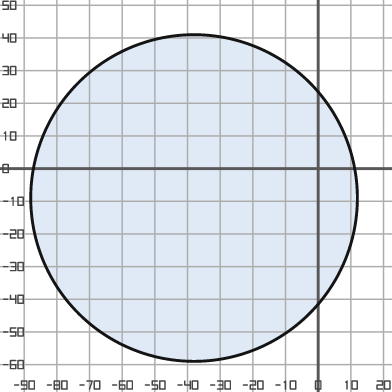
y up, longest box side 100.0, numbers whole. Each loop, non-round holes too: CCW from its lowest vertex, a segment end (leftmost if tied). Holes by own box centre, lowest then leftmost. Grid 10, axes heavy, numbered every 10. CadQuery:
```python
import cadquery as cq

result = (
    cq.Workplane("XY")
    .moveTo(-38.0, -9.0)
    .circle(50.0)
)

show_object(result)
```